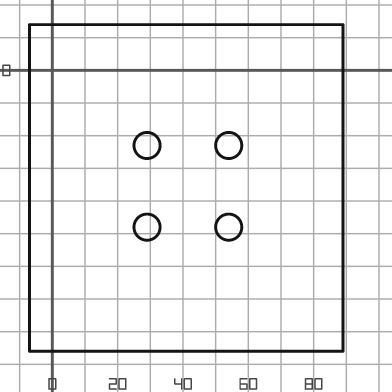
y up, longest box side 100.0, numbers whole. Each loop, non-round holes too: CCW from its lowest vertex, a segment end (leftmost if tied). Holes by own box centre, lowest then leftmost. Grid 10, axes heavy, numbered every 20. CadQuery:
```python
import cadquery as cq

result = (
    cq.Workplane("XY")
    .moveTo(-7.0, -86.0)
    .lineTo(89.0, -86.0)
    .lineTo(89.0, 14.0)
    .lineTo(-7.0, 14.0)
    .close()
    .moveTo(29.0, -48.0)
    .circle(4.0)
    .moveTo(54.0, -48.0)
    .circle(4.0)
    .moveTo(29.0, -23.0)
    .circle(4.0)
    .moveTo(54.0, -23.0)
    .circle(4.0)
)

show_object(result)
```